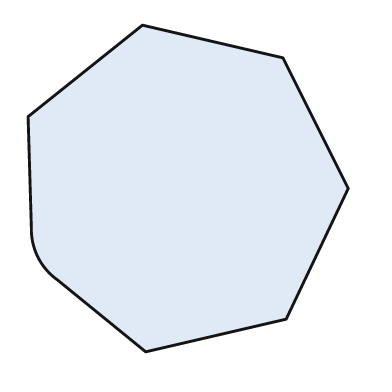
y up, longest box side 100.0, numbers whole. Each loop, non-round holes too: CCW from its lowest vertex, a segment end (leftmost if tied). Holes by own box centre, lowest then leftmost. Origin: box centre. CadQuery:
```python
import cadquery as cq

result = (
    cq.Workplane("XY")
    .moveTo(-13.0, -50.0)
    .lineTo(30.0, -40.0)
    .lineTo(49.0, 0.0)
    .lineTo(29.0, 40.0)
    .lineTo(-14.0, 50.0)
    .lineTo(-49.0, 22.0)
    .lineTo(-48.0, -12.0)
    .threePointArc((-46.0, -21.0), (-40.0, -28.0))
    .close()
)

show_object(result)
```